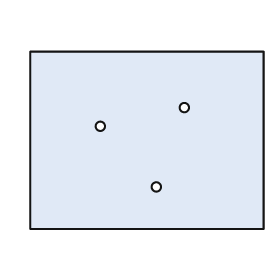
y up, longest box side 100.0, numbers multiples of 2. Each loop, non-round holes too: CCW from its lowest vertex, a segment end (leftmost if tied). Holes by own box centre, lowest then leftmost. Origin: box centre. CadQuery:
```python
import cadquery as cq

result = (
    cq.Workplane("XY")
    .moveTo(-50.0, -38.0)
    .lineTo(50.0, -38.0)
    .lineTo(50.0, 38.0)
    .lineTo(-50.0, 38.0)
    .close()
    .moveTo(4.0, -20.0)
    .circle(2.0)
    .moveTo(-20.0, 6.0)
    .circle(2.0)
    .moveTo(16.0, 14.0)
    .circle(2.0)
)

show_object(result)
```